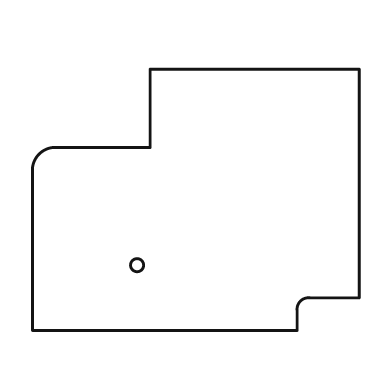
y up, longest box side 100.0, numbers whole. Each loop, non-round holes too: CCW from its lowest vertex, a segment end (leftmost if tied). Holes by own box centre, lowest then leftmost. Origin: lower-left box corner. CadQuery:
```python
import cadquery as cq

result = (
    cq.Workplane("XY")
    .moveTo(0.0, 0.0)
    .lineTo(81.0, 0.0)
    .lineTo(81.0, 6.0)
    .threePointArc((82.0, 9.0), (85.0, 10.0))
    .lineTo(100.0, 10.0)
    .lineTo(100.0, 80.0)
    .lineTo(36.0, 80.0)
    .lineTo(36.0, 56.0)
    .lineTo(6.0, 56.0)
    .threePointArc((2.0, 54.0), (0.0, 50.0))
    .close()
    .moveTo(32.0, 20.0)
    .circle(2.0)
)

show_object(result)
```